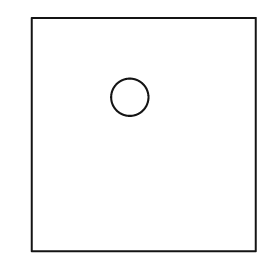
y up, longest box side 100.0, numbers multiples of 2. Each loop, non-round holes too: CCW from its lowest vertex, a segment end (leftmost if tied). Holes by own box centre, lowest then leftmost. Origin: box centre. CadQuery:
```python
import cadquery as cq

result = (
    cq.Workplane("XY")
    .moveTo(-48.0, -50.0)
    .lineTo(48.0, -50.0)
    .lineTo(48.0, 50.0)
    .lineTo(-48.0, 50.0)
    .close()
    .moveTo(-6.0, 16.0)
    .circle(8.0)
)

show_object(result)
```